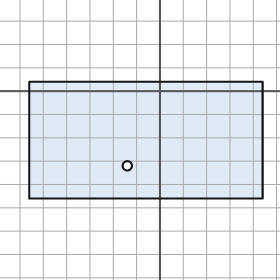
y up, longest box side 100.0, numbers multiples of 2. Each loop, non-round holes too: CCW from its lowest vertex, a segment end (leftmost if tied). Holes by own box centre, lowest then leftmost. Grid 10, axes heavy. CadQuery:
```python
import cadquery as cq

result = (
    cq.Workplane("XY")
    .moveTo(-56.0, -46.0)
    .lineTo(44.0, -46.0)
    .lineTo(44.0, 4.0)
    .lineTo(-56.0, 4.0)
    .close()
    .moveTo(-14.0, -32.0)
    .circle(2.0)
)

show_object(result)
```